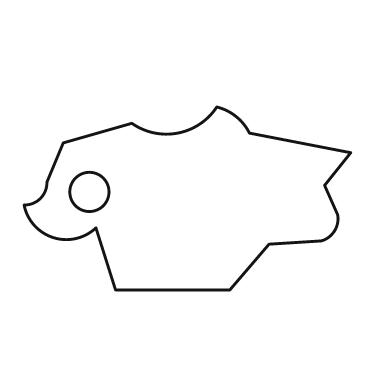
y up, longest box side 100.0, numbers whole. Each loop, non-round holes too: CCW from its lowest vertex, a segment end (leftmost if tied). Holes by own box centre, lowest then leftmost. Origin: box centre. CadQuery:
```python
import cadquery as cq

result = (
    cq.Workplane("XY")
    .moveTo(-22.0, -28.0)
    .lineTo(13.0, -28.0)
    .lineTo(25.0, -14.0)
    .lineTo(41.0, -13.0)
    .threePointArc((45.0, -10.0), (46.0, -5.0))
    .lineTo(42.0, 4.0)
    .lineTo(50.0, 14.0)
    .lineTo(19.0, 20.0)
    .threePointArc((15.0, 25.0), (9.0, 28.0))
    .threePointArc((-3.0, 20.0), (-17.0, 23.0))
    .lineTo(-38.0, 17.0)
    .lineTo(-43.0, 5.0)
    .threePointArc((-45.0, 0.0), (-50.0, -2.0))
    .threePointArc((-41.0, -12.0), (-28.0, -9.0))
    .close()
    .moveTo(-30.0, 2.0)
    .circle(6.0)
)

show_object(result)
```